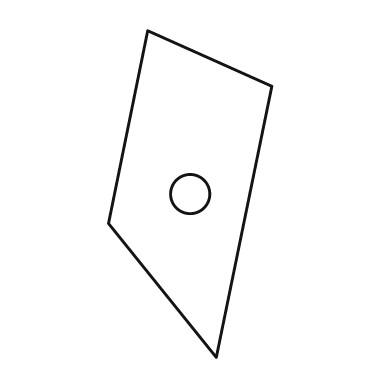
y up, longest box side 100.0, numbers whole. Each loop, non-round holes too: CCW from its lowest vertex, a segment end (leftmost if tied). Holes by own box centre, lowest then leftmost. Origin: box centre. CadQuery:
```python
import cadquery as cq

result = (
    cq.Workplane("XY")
    .moveTo(8.0, -50.0)
    .lineTo(25.0, 33.0)
    .lineTo(-13.0, 50.0)
    .lineTo(-25.0, -9.0)
    .close()
    .moveTo(0.0, 0.0)
    .circle(6.0)
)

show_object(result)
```